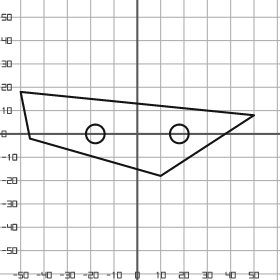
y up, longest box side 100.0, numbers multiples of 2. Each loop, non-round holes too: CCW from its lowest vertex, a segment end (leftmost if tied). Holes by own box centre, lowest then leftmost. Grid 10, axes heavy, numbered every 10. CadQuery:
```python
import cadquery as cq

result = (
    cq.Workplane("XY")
    .moveTo(10.0, -18.0)
    .lineTo(50.0, 8.0)
    .lineTo(-50.0, 18.0)
    .lineTo(-46.0, -2.0)
    .close()
    .moveTo(-18.0, 0.0)
    .circle(4.0)
    .moveTo(18.0, 0.0)
    .circle(4.0)
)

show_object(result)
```